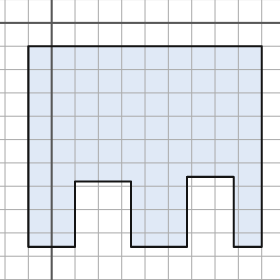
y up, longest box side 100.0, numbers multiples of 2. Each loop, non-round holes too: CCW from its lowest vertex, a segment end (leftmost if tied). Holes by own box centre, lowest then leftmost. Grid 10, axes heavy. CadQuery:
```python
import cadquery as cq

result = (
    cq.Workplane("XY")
    .moveTo(-10.0, -96.0)
    .lineTo(10.0, -96.0)
    .lineTo(10.0, -68.0)
    .lineTo(34.0, -68.0)
    .lineTo(34.0, -96.0)
    .lineTo(58.0, -96.0)
    .lineTo(58.0, -66.0)
    .lineTo(78.0, -66.0)
    .lineTo(78.0, -96.0)
    .lineTo(90.0, -96.0)
    .lineTo(90.0, -10.0)
    .lineTo(-10.0, -10.0)
    .close()
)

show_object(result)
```